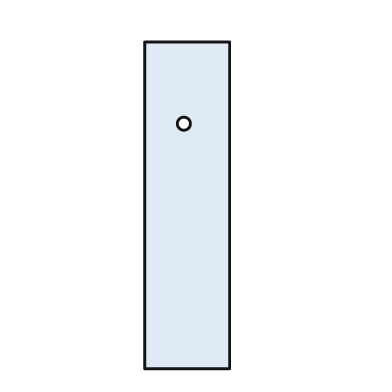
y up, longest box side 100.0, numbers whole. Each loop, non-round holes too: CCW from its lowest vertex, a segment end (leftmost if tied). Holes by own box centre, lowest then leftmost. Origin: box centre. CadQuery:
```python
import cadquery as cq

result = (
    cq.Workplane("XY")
    .moveTo(-13.0, -50.0)
    .lineTo(13.0, -50.0)
    .lineTo(13.0, 50.0)
    .lineTo(-13.0, 50.0)
    .close()
    .moveTo(-1.0, 25.0)
    .circle(2.0)
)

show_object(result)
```